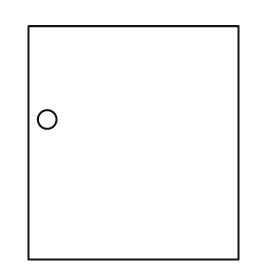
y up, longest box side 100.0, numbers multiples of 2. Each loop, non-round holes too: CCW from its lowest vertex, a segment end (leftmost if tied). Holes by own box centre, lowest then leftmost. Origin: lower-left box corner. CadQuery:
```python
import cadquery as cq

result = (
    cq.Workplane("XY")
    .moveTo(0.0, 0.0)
    .lineTo(90.0, 0.0)
    .lineTo(90.0, 100.0)
    .lineTo(0.0, 100.0)
    .close()
    .moveTo(8.0, 60.0)
    .circle(4.0)
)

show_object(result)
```